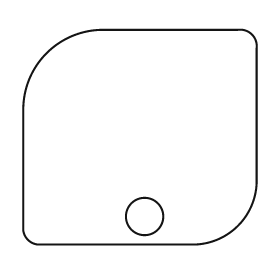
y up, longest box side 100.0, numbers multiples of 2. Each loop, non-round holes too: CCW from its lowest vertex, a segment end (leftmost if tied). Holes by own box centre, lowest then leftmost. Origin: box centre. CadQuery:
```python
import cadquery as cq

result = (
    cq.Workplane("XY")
    .moveTo(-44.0, -46.0)
    .lineTo(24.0, -46.0)
    .threePointArc((42.0, -38.0), (50.0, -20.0))
    .lineTo(50.0, 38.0)
    .threePointArc((48.0, 44.0), (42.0, 46.0))
    .lineTo(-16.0, 46.0)
    .threePointArc((-40.0, 36.0), (-50.0, 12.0))
    .lineTo(-50.0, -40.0)
    .threePointArc((-48.0, -44.0), (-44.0, -46.0))
    .close()
    .moveTo(2.0, -34.0)
    .circle(8.0)
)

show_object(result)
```